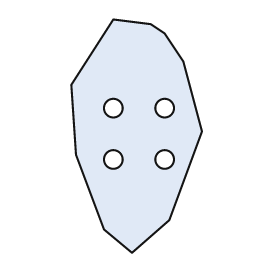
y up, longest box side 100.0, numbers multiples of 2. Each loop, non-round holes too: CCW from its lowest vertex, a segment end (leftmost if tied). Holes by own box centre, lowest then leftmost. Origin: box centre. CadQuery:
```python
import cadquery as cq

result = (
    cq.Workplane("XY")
    .moveTo(-2.0, -50.0)
    .lineTo(14.0, -36.0)
    .lineTo(28.0, 2.0)
    .lineTo(20.0, 32.0)
    .lineTo(12.0, 44.0)
    .lineTo(6.0, 48.0)
    .lineTo(-10.0, 50.0)
    .lineTo(-28.0, 22.0)
    .lineTo(-26.0, -8.0)
    .lineTo(-14.0, -40.0)
    .close()
    .moveTo(-10.0, -10.0)
    .circle(4.0)
    .moveTo(12.0, -10.0)
    .circle(4.0)
    .moveTo(-10.0, 12.0)
    .circle(4.0)
    .moveTo(12.0, 12.0)
    .circle(4.0)
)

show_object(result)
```